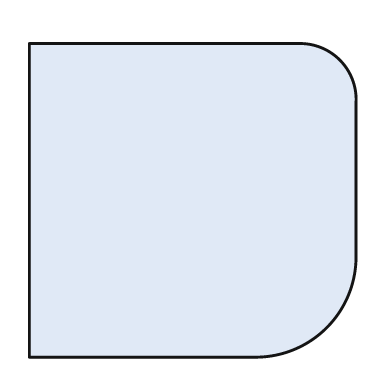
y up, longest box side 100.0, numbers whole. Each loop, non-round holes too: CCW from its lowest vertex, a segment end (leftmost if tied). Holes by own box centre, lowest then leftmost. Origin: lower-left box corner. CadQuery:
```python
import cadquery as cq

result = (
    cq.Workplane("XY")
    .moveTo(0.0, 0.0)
    .lineTo(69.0, 0.0)
    .threePointArc((91.0, 9.0), (100.0, 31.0))
    .lineTo(100.0, 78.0)
    .threePointArc((95.0, 91.0), (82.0, 96.0))
    .lineTo(0.0, 96.0)
    .close()
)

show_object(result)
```